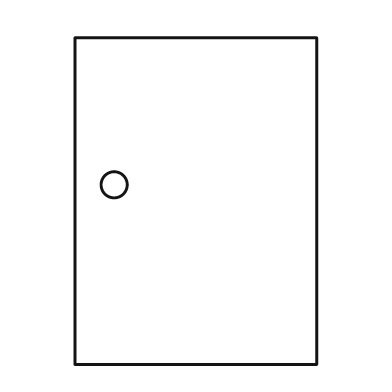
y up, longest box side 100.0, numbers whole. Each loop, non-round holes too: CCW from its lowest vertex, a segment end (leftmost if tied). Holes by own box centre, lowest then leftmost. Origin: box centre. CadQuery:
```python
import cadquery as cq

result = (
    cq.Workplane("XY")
    .moveTo(-37.0, -50.0)
    .lineTo(37.0, -50.0)
    .lineTo(37.0, 50.0)
    .lineTo(-37.0, 50.0)
    .close()
    .moveTo(-25.0, 5.0)
    .circle(4.0)
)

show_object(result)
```